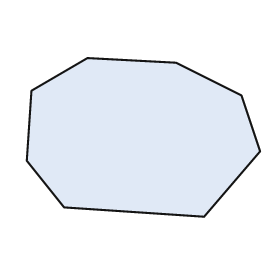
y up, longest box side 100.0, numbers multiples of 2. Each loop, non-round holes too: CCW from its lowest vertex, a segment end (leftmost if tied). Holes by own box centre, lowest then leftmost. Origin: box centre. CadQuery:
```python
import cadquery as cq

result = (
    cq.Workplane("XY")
    .moveTo(26.0, -34.0)
    .lineTo(50.0, -6.0)
    .lineTo(42.0, 18.0)
    .lineTo(14.0, 32.0)
    .lineTo(-24.0, 34.0)
    .lineTo(-48.0, 20.0)
    .lineTo(-50.0, -10.0)
    .lineTo(-34.0, -30.0)
    .close()
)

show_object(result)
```